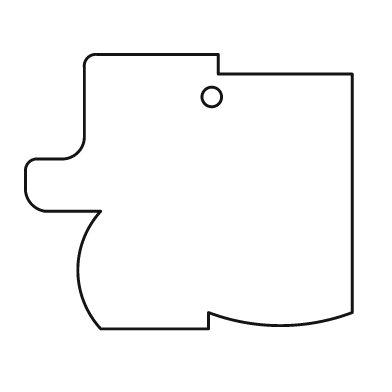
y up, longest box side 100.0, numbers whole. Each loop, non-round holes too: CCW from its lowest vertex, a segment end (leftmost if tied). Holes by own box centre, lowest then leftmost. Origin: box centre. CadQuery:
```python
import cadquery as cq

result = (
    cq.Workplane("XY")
    .moveTo(-27.0, -42.0)
    .lineTo(6.0, -42.0)
    .lineTo(6.0, -37.0)
    .threePointArc((28.0, -41.0), (50.0, -37.0))
    .lineTo(50.0, 36.0)
    .lineTo(9.0, 36.0)
    .lineTo(9.0, 42.0)
    .lineTo(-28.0, 42.0)
    .threePointArc((-31.0, 41.0), (-32.0, 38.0))
    .lineTo(-32.0, 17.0)
    .threePointArc((-34.0, 12.0), (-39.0, 10.0))
    .lineTo(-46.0, 10.0)
    .threePointArc((-49.0, 9.0), (-50.0, 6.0))
    .lineTo(-50.0, 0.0)
    .threePointArc((-48.0, -4.0), (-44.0, -6.0))
    .lineTo(-27.0, -6.0)
    .threePointArc((-34.0, -24.0), (-27.0, -42.0))
    .close()
    .moveTo(7.0, 29.0)
    .circle(3.0)
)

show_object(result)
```